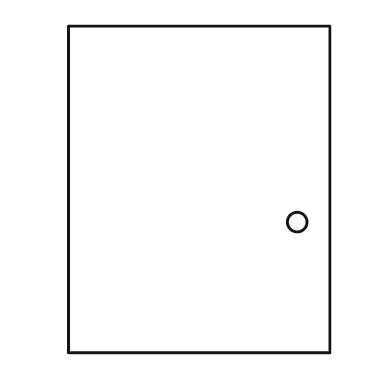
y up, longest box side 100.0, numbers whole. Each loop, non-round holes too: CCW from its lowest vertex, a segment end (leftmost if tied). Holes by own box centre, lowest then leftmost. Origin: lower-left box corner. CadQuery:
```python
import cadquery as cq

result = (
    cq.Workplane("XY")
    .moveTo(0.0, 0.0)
    .lineTo(80.0, 0.0)
    .lineTo(80.0, 100.0)
    .lineTo(0.0, 100.0)
    .close()
    .moveTo(70.0, 40.0)
    .circle(3.0)
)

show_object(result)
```